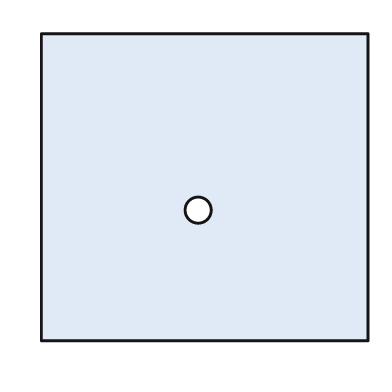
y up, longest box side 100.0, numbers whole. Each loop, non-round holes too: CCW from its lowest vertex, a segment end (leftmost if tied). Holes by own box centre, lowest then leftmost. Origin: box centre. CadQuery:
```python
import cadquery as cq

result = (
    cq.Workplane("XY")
    .moveTo(-50.0, -47.0)
    .lineTo(50.0, -47.0)
    .lineTo(50.0, 47.0)
    .lineTo(-50.0, 47.0)
    .close()
    .moveTo(-2.0, -7.0)
    .circle(4.0)
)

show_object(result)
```